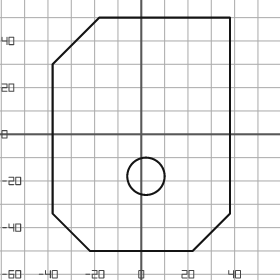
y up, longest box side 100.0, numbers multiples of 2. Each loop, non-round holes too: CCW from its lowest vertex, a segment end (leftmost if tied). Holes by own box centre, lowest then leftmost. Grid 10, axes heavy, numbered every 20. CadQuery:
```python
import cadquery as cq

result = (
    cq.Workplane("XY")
    .moveTo(-22.0, -50.0)
    .lineTo(22.0, -50.0)
    .lineTo(38.0, -34.0)
    .lineTo(38.0, 50.0)
    .lineTo(-18.0, 50.0)
    .lineTo(-38.0, 30.0)
    .lineTo(-38.0, -34.0)
    .close()
    .moveTo(2.0, -18.0)
    .circle(8.0)
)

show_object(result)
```